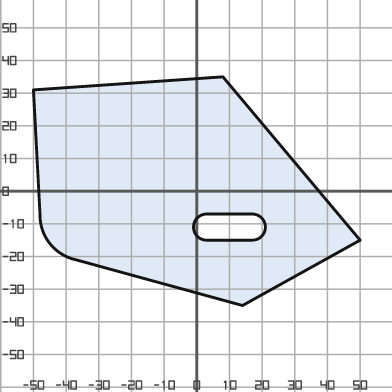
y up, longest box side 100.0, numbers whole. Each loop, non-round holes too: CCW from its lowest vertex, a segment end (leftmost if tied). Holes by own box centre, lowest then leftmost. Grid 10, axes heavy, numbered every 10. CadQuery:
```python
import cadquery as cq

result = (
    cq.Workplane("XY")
    .moveTo(14.0, -35.0)
    .lineTo(50.0, -15.0)
    .lineTo(8.0, 35.0)
    .lineTo(-50.0, 31.0)
    .lineTo(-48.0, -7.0)
    .threePointArc((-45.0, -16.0), (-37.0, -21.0))
    .close()
    .moveTo(3.0, -15.0)
    .lineTo(17.0, -15.0)
    .threePointArc((21.0, -11.0), (17.0, -7.0))
    .lineTo(3.0, -7.0)
    .threePointArc((-1.0, -11.0), (3.0, -15.0))
    .close()
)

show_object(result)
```